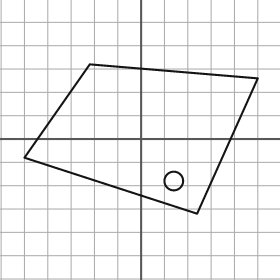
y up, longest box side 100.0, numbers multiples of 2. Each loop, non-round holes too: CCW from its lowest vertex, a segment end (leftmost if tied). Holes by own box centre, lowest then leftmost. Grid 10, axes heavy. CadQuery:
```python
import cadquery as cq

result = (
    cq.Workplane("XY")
    .moveTo(24.0, -32.0)
    .lineTo(50.0, 26.0)
    .lineTo(-22.0, 32.0)
    .lineTo(-50.0, -8.0)
    .close()
    .moveTo(14.0, -18.0)
    .circle(4.0)
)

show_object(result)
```